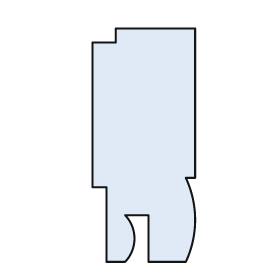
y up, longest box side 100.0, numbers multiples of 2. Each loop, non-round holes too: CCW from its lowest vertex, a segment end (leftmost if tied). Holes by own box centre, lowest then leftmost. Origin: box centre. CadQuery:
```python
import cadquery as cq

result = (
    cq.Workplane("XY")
    .moveTo(-16.0, -50.0)
    .lineTo(-8.0, -50.0)
    .threePointArc((-4.0, -40.0), (-8.0, -30.0))
    .lineTo(2.0, -30.0)
    .lineTo(2.0, -50.0)
    .lineTo(18.0, -50.0)
    .threePointArc((22.0, -32.0), (18.0, -14.0))
    .lineTo(22.0, -14.0)
    .lineTo(22.0, 50.0)
    .lineTo(-12.0, 50.0)
    .lineTo(-12.0, 44.0)
    .lineTo(-22.0, 44.0)
    .lineTo(-22.0, -18.0)
    .lineTo(-16.0, -18.0)
    .close()
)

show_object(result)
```